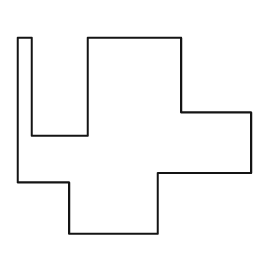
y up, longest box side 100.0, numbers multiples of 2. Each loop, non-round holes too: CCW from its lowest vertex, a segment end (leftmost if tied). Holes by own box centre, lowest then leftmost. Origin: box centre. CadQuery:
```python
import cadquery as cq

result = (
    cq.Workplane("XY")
    .moveTo(-28.0, -42.0)
    .lineTo(10.0, -42.0)
    .lineTo(10.0, -16.0)
    .lineTo(50.0, -16.0)
    .lineTo(50.0, 10.0)
    .lineTo(20.0, 10.0)
    .lineTo(20.0, 42.0)
    .lineTo(-20.0, 42.0)
    .lineTo(-20.0, 0.0)
    .lineTo(-44.0, 0.0)
    .lineTo(-44.0, 42.0)
    .lineTo(-50.0, 42.0)
    .lineTo(-50.0, -20.0)
    .lineTo(-28.0, -20.0)
    .close()
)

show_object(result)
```